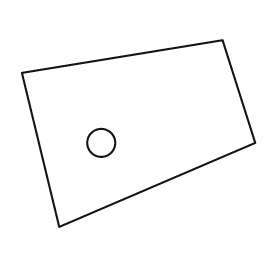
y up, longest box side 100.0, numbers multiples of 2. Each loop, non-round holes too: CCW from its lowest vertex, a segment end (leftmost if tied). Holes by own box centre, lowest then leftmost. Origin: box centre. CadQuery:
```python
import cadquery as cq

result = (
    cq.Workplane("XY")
    .moveTo(-34.0, -40.0)
    .lineTo(50.0, -4.0)
    .lineTo(36.0, 40.0)
    .lineTo(-50.0, 26.0)
    .close()
    .moveTo(-16.0, -4.0)
    .circle(6.0)
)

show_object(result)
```